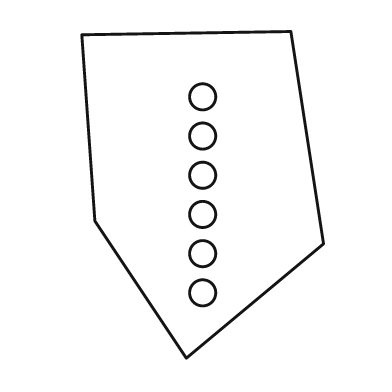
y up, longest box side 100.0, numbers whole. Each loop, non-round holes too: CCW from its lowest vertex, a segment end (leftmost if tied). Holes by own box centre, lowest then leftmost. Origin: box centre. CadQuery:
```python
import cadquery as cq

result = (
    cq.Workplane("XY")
    .moveTo(-5.0, -50.0)
    .lineTo(37.0, -15.0)
    .lineTo(27.0, 50.0)
    .lineTo(-37.0, 49.0)
    .lineTo(-33.0, -8.0)
    .close()
    .moveTo(0.0, -30.0)
    .circle(4.0)
    .moveTo(0.0, -18.0)
    .circle(4.0)
    .moveTo(0.0, -6.0)
    .circle(4.0)
    .moveTo(0.0, 6.0)
    .circle(4.0)
    .moveTo(0.0, 18.0)
    .circle(4.0)
    .moveTo(0.0, 30.0)
    .circle(4.0)
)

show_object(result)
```